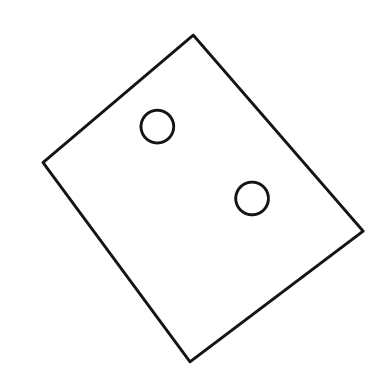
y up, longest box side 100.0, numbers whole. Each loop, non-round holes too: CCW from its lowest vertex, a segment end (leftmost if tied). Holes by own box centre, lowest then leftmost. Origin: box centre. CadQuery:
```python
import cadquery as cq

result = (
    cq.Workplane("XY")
    .moveTo(-4.0, -50.0)
    .lineTo(49.0, -10.0)
    .lineTo(-3.0, 50.0)
    .lineTo(-49.0, 11.0)
    .close()
    .moveTo(15.0, 0.0)
    .circle(5.0)
    .moveTo(-14.0, 22.0)
    .circle(5.0)
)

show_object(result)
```